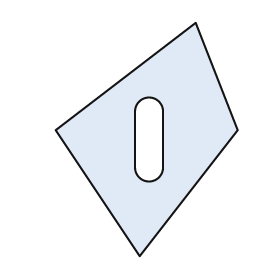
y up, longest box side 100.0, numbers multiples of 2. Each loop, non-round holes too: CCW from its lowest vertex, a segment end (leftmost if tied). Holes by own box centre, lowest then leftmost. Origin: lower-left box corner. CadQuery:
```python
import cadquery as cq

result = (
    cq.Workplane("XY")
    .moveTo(36.0, 0.0)
    .lineTo(78.0, 54.0)
    .lineTo(60.0, 100.0)
    .lineTo(0.0, 54.0)
    .close()
    .moveTo(34.0, 38.0)
    .threePointArc((40.0, 32.0), (46.0, 38.0))
    .lineTo(46.0, 62.0)
    .threePointArc((40.0, 68.0), (34.0, 62.0))
    .close()
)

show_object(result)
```